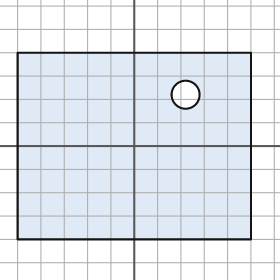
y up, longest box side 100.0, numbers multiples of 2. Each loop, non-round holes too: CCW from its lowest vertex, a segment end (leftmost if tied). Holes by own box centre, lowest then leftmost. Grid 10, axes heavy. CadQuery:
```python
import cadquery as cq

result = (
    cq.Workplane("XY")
    .moveTo(-50.0, -40.0)
    .lineTo(50.0, -40.0)
    .lineTo(50.0, 40.0)
    .lineTo(-50.0, 40.0)
    .close()
    .moveTo(22.0, 22.0)
    .circle(6.0)
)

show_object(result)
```